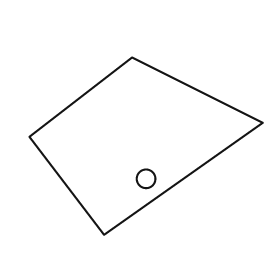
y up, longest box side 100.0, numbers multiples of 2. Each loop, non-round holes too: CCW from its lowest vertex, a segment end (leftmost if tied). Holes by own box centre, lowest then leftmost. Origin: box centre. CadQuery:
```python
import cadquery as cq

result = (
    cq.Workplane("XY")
    .moveTo(-18.0, -38.0)
    .lineTo(50.0, 10.0)
    .lineTo(-6.0, 38.0)
    .lineTo(-50.0, 4.0)
    .close()
    .moveTo(0.0, -14.0)
    .circle(4.0)
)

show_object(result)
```